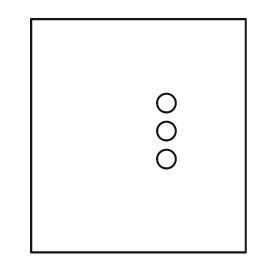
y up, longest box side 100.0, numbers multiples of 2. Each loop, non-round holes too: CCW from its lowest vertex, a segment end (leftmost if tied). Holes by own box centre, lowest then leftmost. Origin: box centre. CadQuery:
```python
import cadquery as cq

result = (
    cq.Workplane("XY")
    .moveTo(-46.0, -50.0)
    .lineTo(46.0, -50.0)
    .lineTo(46.0, 50.0)
    .lineTo(-46.0, 50.0)
    .close()
    .moveTo(12.0, -10.0)
    .circle(4.0)
    .moveTo(12.0, 2.0)
    .circle(4.0)
    .moveTo(12.0, 14.0)
    .circle(4.0)
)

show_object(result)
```